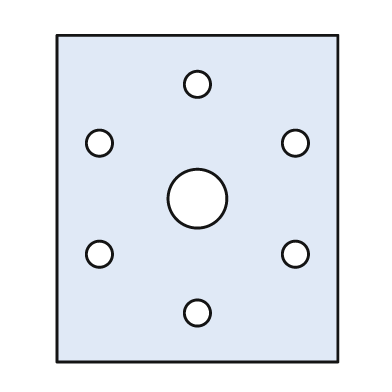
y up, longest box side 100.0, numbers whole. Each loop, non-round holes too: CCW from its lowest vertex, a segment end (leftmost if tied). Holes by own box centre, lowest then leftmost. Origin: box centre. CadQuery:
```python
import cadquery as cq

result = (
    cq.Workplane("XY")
    .moveTo(-43.0, -50.0)
    .lineTo(43.0, -50.0)
    .lineTo(43.0, 50.0)
    .lineTo(-43.0, 50.0)
    .close()
    .moveTo(0.0, -35.0)
    .circle(4.0)
    .moveTo(-30.0, -17.0)
    .circle(4.0)
    .moveTo(30.0, -17.0)
    .circle(4.0)
    .moveTo(0.0, 0.0)
    .circle(9.0)
    .moveTo(-30.0, 17.0)
    .circle(4.0)
    .moveTo(30.0, 17.0)
    .circle(4.0)
    .moveTo(0.0, 35.0)
    .circle(4.0)
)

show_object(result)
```